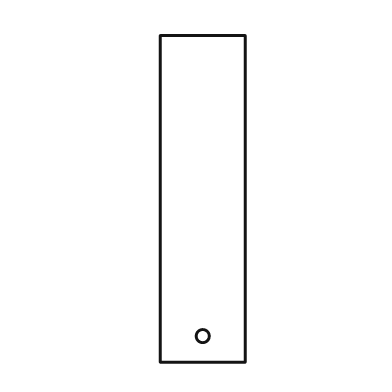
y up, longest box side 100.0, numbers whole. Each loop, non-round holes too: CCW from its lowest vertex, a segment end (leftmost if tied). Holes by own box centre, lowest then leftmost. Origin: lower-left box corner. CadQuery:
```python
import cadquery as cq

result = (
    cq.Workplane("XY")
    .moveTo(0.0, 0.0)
    .lineTo(26.0, 0.0)
    .lineTo(26.0, 100.0)
    .lineTo(0.0, 100.0)
    .close()
    .moveTo(13.0, 8.0)
    .circle(2.0)
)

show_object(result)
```